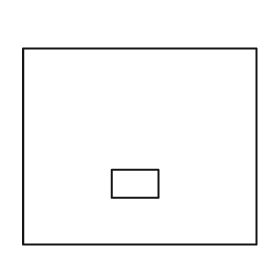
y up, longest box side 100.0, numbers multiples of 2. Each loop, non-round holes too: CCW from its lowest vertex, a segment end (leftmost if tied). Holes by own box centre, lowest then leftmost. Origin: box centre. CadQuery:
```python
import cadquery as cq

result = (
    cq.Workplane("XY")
    .moveTo(-50.0, -42.0)
    .lineTo(50.0, -42.0)
    .lineTo(50.0, 42.0)
    .lineTo(-50.0, 42.0)
    .close()
    .moveTo(-12.0, -22.0)
    .lineTo(8.0, -22.0)
    .lineTo(8.0, -10.0)
    .lineTo(-12.0, -10.0)
    .close()
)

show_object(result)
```